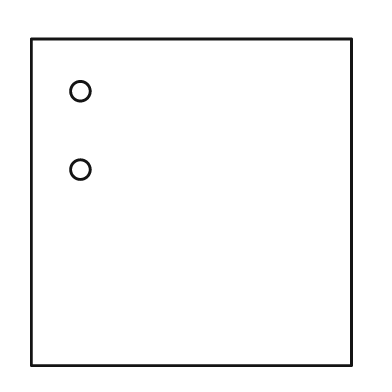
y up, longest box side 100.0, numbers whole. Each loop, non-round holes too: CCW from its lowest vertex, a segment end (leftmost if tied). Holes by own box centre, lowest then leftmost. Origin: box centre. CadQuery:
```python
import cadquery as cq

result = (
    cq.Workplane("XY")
    .moveTo(-49.0, -50.0)
    .lineTo(49.0, -50.0)
    .lineTo(49.0, 50.0)
    .lineTo(-49.0, 50.0)
    .close()
    .moveTo(-34.0, 10.0)
    .circle(3.0)
    .moveTo(-34.0, 34.0)
    .circle(3.0)
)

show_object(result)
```